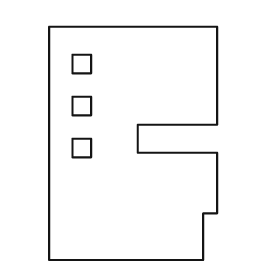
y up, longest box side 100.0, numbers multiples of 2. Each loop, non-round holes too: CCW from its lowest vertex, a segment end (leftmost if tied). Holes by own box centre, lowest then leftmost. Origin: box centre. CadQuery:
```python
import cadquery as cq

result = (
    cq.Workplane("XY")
    .moveTo(-36.0, -50.0)
    .lineTo(30.0, -50.0)
    .lineTo(30.0, -30.0)
    .lineTo(36.0, -30.0)
    .lineTo(36.0, -4.0)
    .lineTo(2.0, -4.0)
    .lineTo(2.0, 8.0)
    .lineTo(36.0, 8.0)
    .lineTo(36.0, 50.0)
    .lineTo(-36.0, 50.0)
    .close()
    .moveTo(-26.0, -6.0)
    .lineTo(-18.0, -6.0)
    .lineTo(-18.0, 2.0)
    .lineTo(-26.0, 2.0)
    .close()
    .moveTo(-26.0, 12.0)
    .lineTo(-18.0, 12.0)
    .lineTo(-18.0, 20.0)
    .lineTo(-26.0, 20.0)
    .close()
    .moveTo(-26.0, 30.0)
    .lineTo(-18.0, 30.0)
    .lineTo(-18.0, 38.0)
    .lineTo(-26.0, 38.0)
    .close()
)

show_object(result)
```